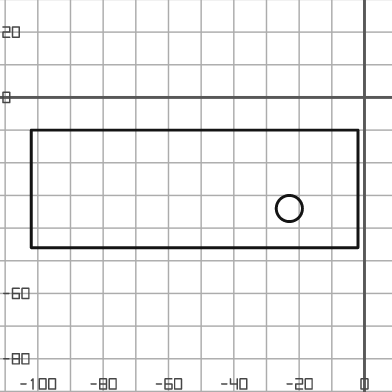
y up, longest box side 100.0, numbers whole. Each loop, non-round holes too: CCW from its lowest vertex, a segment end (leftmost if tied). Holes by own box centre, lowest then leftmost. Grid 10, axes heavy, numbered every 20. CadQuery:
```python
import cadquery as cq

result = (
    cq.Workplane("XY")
    .moveTo(-102.0, -46.0)
    .lineTo(-2.0, -46.0)
    .lineTo(-2.0, -10.0)
    .lineTo(-102.0, -10.0)
    .close()
    .moveTo(-23.0, -34.0)
    .circle(4.0)
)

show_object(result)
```